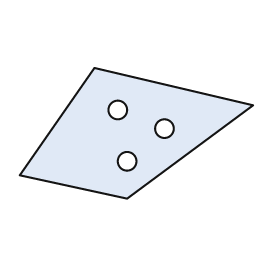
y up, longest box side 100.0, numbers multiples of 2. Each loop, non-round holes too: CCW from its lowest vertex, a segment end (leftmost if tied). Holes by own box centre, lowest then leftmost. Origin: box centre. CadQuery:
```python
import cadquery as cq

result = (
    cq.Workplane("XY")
    .moveTo(-4.0, -28.0)
    .lineTo(50.0, 12.0)
    .lineTo(-18.0, 28.0)
    .lineTo(-50.0, -18.0)
    .close()
    .moveTo(-4.0, -12.0)
    .circle(4.0)
    .moveTo(12.0, 2.0)
    .circle(4.0)
    .moveTo(-8.0, 10.0)
    .circle(4.0)
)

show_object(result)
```